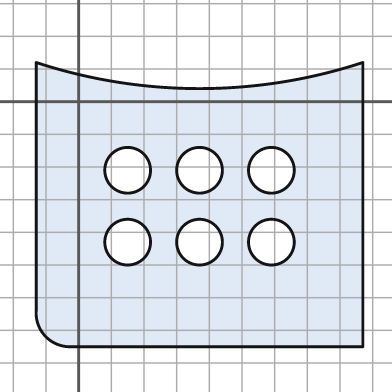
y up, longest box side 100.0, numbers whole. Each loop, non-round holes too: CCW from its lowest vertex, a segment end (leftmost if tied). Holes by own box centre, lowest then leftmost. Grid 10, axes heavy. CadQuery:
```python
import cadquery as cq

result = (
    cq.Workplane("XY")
    .moveTo(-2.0, -75.0)
    .lineTo(87.0, -75.0)
    .lineTo(87.0, 12.0)
    .threePointArc((37.0, 4.0), (-13.0, 12.0))
    .lineTo(-13.0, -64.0)
    .threePointArc((-10.0, -72.0), (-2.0, -75.0))
    .close()
    .moveTo(15.0, -43.0)
    .circle(7.0)
    .moveTo(37.0, -43.0)
    .circle(7.0)
    .moveTo(59.0, -43.0)
    .circle(7.0)
    .moveTo(15.0, -21.0)
    .circle(7.0)
    .moveTo(37.0, -21.0)
    .circle(7.0)
    .moveTo(59.0, -21.0)
    .circle(7.0)
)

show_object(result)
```